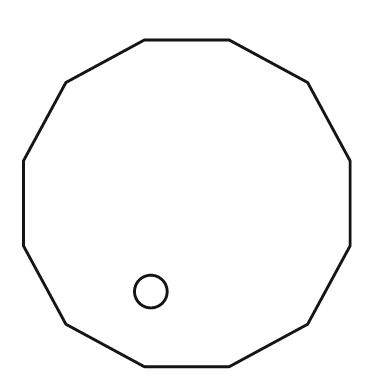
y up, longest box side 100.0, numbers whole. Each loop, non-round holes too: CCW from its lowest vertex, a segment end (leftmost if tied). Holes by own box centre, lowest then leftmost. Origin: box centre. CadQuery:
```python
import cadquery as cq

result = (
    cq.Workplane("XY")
    .moveTo(-13.0, -50.0)
    .lineTo(13.0, -50.0)
    .lineTo(37.0, -37.0)
    .lineTo(50.0, -13.0)
    .lineTo(50.0, 13.0)
    .lineTo(37.0, 37.0)
    .lineTo(13.0, 50.0)
    .lineTo(-13.0, 50.0)
    .lineTo(-37.0, 37.0)
    .lineTo(-50.0, 13.0)
    .lineTo(-50.0, -13.0)
    .lineTo(-37.0, -37.0)
    .close()
    .moveTo(-11.0, -27.0)
    .circle(5.0)
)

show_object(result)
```